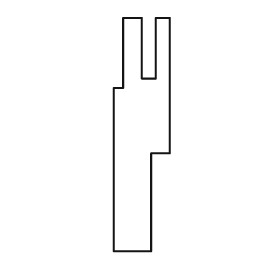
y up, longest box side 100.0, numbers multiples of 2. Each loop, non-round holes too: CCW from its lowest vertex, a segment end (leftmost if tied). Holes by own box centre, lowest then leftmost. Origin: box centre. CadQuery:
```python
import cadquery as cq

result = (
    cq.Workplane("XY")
    .moveTo(-12.0, -50.0)
    .lineTo(4.0, -50.0)
    .lineTo(4.0, -8.0)
    .lineTo(12.0, -8.0)
    .lineTo(12.0, 50.0)
    .lineTo(6.0, 50.0)
    .lineTo(6.0, 24.0)
    .lineTo(0.0, 24.0)
    .lineTo(0.0, 50.0)
    .lineTo(-8.0, 50.0)
    .lineTo(-8.0, 20.0)
    .lineTo(-12.0, 20.0)
    .close()
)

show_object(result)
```